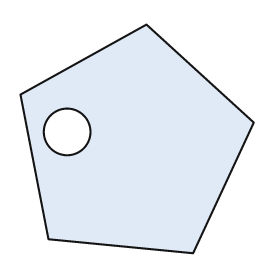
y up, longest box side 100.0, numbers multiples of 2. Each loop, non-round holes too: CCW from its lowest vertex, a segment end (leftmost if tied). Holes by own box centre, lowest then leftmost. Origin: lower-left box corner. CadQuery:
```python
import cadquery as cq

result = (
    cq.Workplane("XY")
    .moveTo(74.0, 0.0)
    .lineTo(100.0, 56.0)
    .lineTo(54.0, 98.0)
    .lineTo(0.0, 68.0)
    .lineTo(12.0, 6.0)
    .close()
    .moveTo(20.0, 52.0)
    .circle(10.0)
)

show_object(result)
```